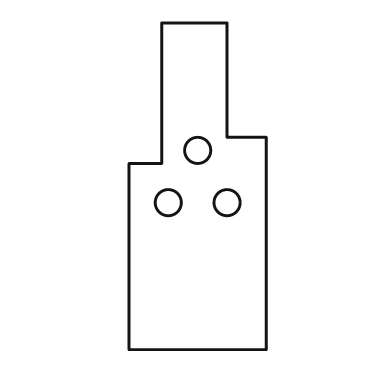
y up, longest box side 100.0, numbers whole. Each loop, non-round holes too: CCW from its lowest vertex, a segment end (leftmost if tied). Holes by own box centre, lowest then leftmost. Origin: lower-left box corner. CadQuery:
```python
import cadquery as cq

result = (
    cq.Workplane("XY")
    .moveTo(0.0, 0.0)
    .lineTo(42.0, 0.0)
    .lineTo(42.0, 65.0)
    .lineTo(30.0, 65.0)
    .lineTo(30.0, 100.0)
    .lineTo(10.0, 100.0)
    .lineTo(10.0, 57.0)
    .lineTo(0.0, 57.0)
    .close()
    .moveTo(12.0, 45.0)
    .circle(4.0)
    .moveTo(30.0, 45.0)
    .circle(4.0)
    .moveTo(21.0, 61.0)
    .circle(4.0)
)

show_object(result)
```